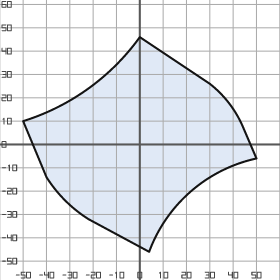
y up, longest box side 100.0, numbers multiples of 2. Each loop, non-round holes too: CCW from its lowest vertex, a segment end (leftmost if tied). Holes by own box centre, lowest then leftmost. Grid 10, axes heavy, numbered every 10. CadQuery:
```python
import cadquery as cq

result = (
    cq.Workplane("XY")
    .moveTo(4.0, -46.0)
    .threePointArc((22.0, -20.0), (50.0, -6.0))
    .lineTo(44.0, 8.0)
    .threePointArc((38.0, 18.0), (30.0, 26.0))
    .lineTo(0.0, 46.0)
    .threePointArc((-22.0, 24.0), (-50.0, 10.0))
    .lineTo(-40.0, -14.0)
    .threePointArc((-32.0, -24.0), (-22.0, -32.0))
    .close()
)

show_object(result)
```